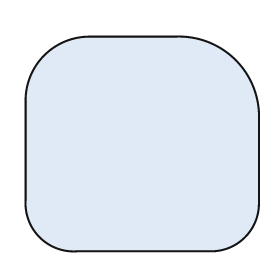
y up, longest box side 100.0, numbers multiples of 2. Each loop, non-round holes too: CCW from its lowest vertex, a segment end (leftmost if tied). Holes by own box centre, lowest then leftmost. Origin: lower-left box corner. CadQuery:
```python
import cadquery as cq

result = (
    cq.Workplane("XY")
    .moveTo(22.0, 0.0)
    .lineTo(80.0, 0.0)
    .threePointArc((94.0, 6.0), (100.0, 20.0))
    .lineTo(100.0, 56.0)
    .threePointArc((90.0, 82.0), (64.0, 92.0))
    .lineTo(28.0, 92.0)
    .threePointArc((8.0, 84.0), (0.0, 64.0))
    .lineTo(0.0, 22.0)
    .threePointArc((6.0, 6.0), (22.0, 0.0))
    .close()
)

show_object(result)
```